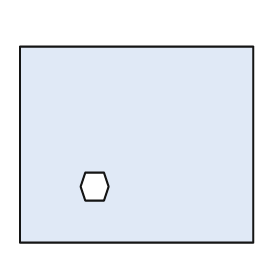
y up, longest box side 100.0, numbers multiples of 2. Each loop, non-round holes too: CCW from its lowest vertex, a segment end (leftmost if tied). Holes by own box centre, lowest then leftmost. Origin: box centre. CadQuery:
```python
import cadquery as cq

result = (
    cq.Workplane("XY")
    .moveTo(-50.0, -42.0)
    .lineTo(50.0, -42.0)
    .lineTo(50.0, 42.0)
    .lineTo(-50.0, 42.0)
    .close()
    .moveTo(-22.0, -24.0)
    .lineTo(-14.0, -24.0)
    .lineTo(-12.0, -18.0)
    .lineTo(-14.0, -12.0)
    .lineTo(-22.0, -12.0)
    .lineTo(-24.0, -18.0)
    .close()
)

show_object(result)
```